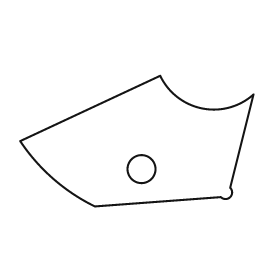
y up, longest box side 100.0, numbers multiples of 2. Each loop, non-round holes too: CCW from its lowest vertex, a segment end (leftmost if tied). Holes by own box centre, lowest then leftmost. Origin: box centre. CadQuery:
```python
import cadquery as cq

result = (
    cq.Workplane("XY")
    .moveTo(-18.0, -28.0)
    .lineTo(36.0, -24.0)
    .threePointArc((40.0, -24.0), (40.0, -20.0))
    .lineTo(50.0, 20.0)
    .threePointArc((28.0, 14.0), (10.0, 28.0))
    .lineTo(-50.0, 0.0)
    .threePointArc((-36.0, -16.0), (-18.0, -28.0))
    .close()
    .moveTo(2.0, -12.0)
    .circle(6.0)
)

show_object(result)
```